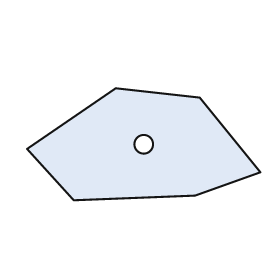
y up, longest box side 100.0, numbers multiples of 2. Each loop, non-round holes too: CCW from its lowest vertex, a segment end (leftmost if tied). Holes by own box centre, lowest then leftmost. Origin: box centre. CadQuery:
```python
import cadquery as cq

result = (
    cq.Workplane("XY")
    .moveTo(-30.0, -24.0)
    .lineTo(22.0, -22.0)
    .lineTo(50.0, -12.0)
    .lineTo(24.0, 20.0)
    .lineTo(-12.0, 24.0)
    .lineTo(-50.0, -2.0)
    .close()
    .moveTo(0.0, 0.0)
    .circle(4.0)
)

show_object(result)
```